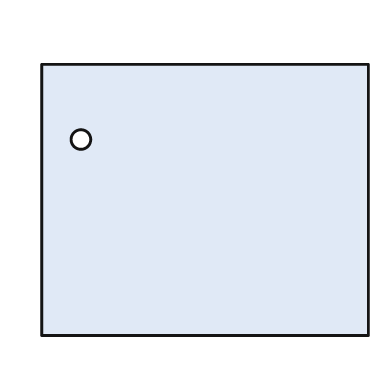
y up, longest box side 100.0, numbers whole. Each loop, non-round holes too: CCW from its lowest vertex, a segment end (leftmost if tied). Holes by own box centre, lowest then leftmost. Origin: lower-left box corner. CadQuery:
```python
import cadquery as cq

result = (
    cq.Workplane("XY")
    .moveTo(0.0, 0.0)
    .lineTo(100.0, 0.0)
    .lineTo(100.0, 83.0)
    .lineTo(0.0, 83.0)
    .close()
    .moveTo(12.0, 60.0)
    .circle(3.0)
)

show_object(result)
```